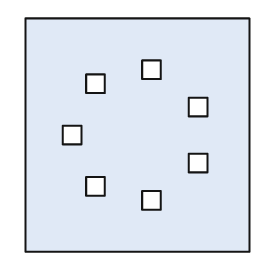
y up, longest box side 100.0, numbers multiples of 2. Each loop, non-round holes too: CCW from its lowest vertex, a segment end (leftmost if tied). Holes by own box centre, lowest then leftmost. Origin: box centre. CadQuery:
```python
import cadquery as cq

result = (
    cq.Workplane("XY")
    .moveTo(-48.0, -50.0)
    .lineTo(48.0, -50.0)
    .lineTo(48.0, 50.0)
    .lineTo(-48.0, 50.0)
    .close()
    .moveTo(2.0, -32.0)
    .lineTo(10.0, -32.0)
    .lineTo(10.0, -24.0)
    .lineTo(2.0, -24.0)
    .close()
    .moveTo(-22.0, -26.0)
    .lineTo(-14.0, -26.0)
    .lineTo(-14.0, -18.0)
    .lineTo(-22.0, -18.0)
    .close()
    .moveTo(22.0, -16.0)
    .lineTo(30.0, -16.0)
    .lineTo(30.0, -8.0)
    .lineTo(22.0, -8.0)
    .close()
    .moveTo(-32.0, -4.0)
    .lineTo(-24.0, -4.0)
    .lineTo(-24.0, 4.0)
    .lineTo(-32.0, 4.0)
    .close()
    .moveTo(22.0, 8.0)
    .lineTo(30.0, 8.0)
    .lineTo(30.0, 16.0)
    .lineTo(22.0, 16.0)
    .close()
    .moveTo(-22.0, 18.0)
    .lineTo(-14.0, 18.0)
    .lineTo(-14.0, 26.0)
    .lineTo(-22.0, 26.0)
    .close()
    .moveTo(2.0, 24.0)
    .lineTo(10.0, 24.0)
    .lineTo(10.0, 32.0)
    .lineTo(2.0, 32.0)
    .close()
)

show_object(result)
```